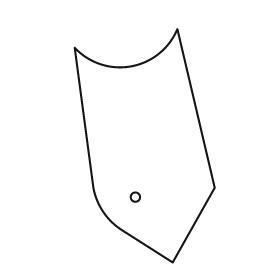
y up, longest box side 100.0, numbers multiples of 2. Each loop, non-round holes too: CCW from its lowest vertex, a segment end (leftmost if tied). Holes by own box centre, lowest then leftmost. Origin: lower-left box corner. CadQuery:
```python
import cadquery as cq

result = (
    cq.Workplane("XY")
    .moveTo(42.0, 0.0)
    .lineTo(60.0, 32.0)
    .lineTo(44.0, 100.0)
    .threePointArc((24.0, 84.0), (0.0, 92.0))
    .lineTo(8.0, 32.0)
    .threePointArc((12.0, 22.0), (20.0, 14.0))
    .close()
    .moveTo(26.0, 28.0)
    .circle(2.0)
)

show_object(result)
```